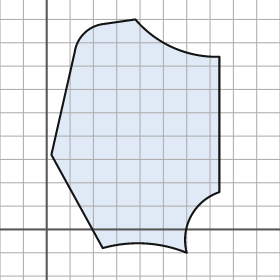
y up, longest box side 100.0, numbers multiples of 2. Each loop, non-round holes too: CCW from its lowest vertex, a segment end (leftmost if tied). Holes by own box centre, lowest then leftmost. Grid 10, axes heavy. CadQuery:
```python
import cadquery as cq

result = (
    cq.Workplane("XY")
    .moveTo(60.0, -10.0)
    .threePointArc((62.0, 6.0), (74.0, 16.0))
    .lineTo(74.0, 74.0)
    .threePointArc((54.0, 78.0), (38.0, 90.0))
    .lineTo(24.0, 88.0)
    .threePointArc((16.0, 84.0), (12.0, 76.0))
    .lineTo(2.0, 32.0)
    .lineTo(24.0, -8.0)
    .threePointArc((42.0, -6.0), (60.0, -10.0))
    .close()
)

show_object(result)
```